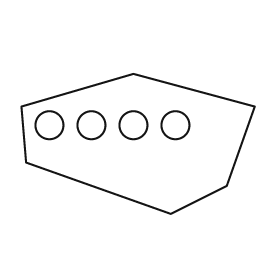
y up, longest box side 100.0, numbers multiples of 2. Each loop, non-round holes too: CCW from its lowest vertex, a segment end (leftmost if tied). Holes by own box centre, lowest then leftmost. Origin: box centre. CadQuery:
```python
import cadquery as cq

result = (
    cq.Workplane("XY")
    .moveTo(14.0, -30.0)
    .lineTo(38.0, -18.0)
    .lineTo(50.0, 16.0)
    .lineTo(-2.0, 30.0)
    .lineTo(-50.0, 16.0)
    .lineTo(-48.0, -8.0)
    .close()
    .moveTo(-38.0, 8.0)
    .circle(6.0)
    .moveTo(-20.0, 8.0)
    .circle(6.0)
    .moveTo(-2.0, 8.0)
    .circle(6.0)
    .moveTo(16.0, 8.0)
    .circle(6.0)
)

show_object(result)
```